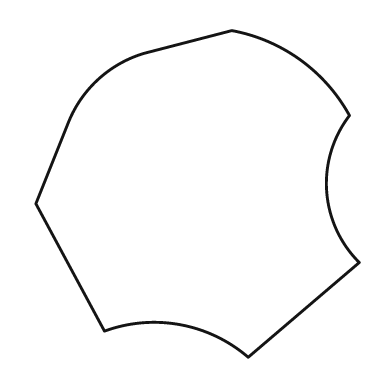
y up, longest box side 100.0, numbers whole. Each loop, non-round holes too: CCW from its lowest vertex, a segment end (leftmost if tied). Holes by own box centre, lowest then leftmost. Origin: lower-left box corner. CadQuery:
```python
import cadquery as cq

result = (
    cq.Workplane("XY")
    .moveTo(65.0, 0.0)
    .lineTo(99.0, 29.0)
    .threePointArc((89.0, 51.0), (96.0, 74.0))
    .threePointArc((81.0, 91.0), (60.0, 100.0))
    .lineTo(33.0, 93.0)
    .threePointArc((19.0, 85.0), (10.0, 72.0))
    .lineTo(0.0, 47.0)
    .lineTo(21.0, 8.0)
    .threePointArc((44.0, 10.0), (65.0, 0.0))
    .close()
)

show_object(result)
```